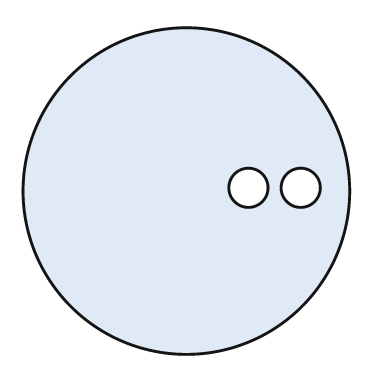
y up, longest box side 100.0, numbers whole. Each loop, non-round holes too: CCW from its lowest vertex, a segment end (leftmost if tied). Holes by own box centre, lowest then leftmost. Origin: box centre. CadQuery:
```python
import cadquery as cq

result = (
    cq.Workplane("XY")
    .moveTo(0.0, 0.0)
    .circle(50.0)
    .moveTo(19.0, 1.0)
    .circle(6.0)
    .moveTo(35.0, 1.0)
    .circle(6.0)
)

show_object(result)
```